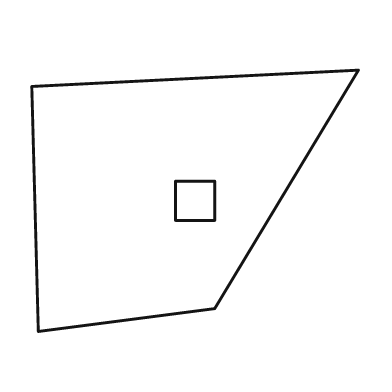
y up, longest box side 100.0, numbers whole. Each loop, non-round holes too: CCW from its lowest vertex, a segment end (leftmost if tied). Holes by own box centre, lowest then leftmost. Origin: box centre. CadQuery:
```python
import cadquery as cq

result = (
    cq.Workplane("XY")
    .moveTo(-48.0, -40.0)
    .lineTo(6.0, -33.0)
    .lineTo(50.0, 40.0)
    .lineTo(-50.0, 35.0)
    .close()
    .moveTo(-6.0, -6.0)
    .lineTo(6.0, -6.0)
    .lineTo(6.0, 6.0)
    .lineTo(-6.0, 6.0)
    .close()
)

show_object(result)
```